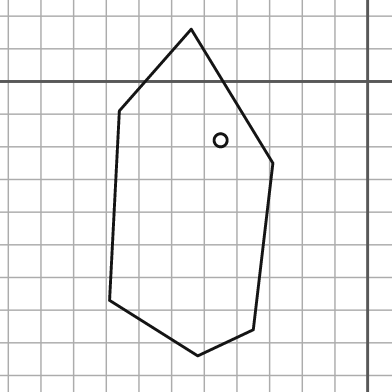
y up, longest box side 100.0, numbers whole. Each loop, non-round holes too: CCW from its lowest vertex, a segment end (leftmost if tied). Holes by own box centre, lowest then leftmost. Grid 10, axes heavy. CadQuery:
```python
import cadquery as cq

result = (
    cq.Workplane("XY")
    .moveTo(-52.0, -84.0)
    .lineTo(-35.0, -76.0)
    .lineTo(-29.0, -25.0)
    .lineTo(-54.0, 16.0)
    .lineTo(-76.0, -9.0)
    .lineTo(-79.0, -67.0)
    .close()
    .moveTo(-45.0, -18.0)
    .circle(2.0)
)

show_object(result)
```